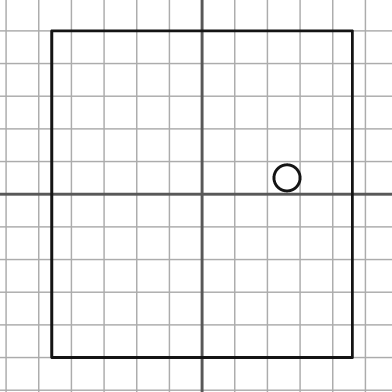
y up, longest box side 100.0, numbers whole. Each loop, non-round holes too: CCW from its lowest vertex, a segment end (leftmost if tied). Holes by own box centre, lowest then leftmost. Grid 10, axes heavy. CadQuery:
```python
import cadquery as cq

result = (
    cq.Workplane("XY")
    .moveTo(-46.0, -50.0)
    .lineTo(46.0, -50.0)
    .lineTo(46.0, 50.0)
    .lineTo(-46.0, 50.0)
    .close()
    .moveTo(26.0, 5.0)
    .circle(4.0)
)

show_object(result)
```